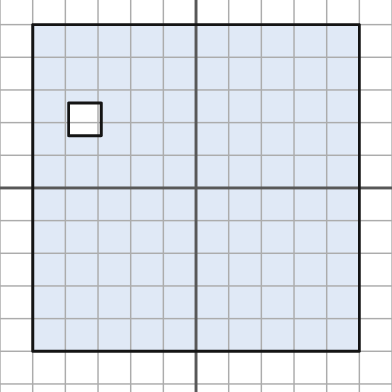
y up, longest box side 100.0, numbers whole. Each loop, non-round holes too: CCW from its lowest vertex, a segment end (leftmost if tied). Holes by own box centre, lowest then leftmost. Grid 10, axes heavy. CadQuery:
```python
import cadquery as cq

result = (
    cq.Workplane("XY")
    .moveTo(-50.0, -50.0)
    .lineTo(50.0, -50.0)
    .lineTo(50.0, 50.0)
    .lineTo(-50.0, 50.0)
    .close()
    .moveTo(-39.0, 16.0)
    .lineTo(-29.0, 16.0)
    .lineTo(-29.0, 26.0)
    .lineTo(-39.0, 26.0)
    .close()
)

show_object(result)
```